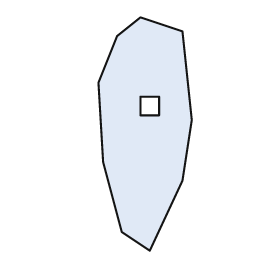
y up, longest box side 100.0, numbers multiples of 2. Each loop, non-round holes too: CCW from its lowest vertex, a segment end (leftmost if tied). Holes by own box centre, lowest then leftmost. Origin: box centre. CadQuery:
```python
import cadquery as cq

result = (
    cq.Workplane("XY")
    .moveTo(2.0, -50.0)
    .lineTo(16.0, -20.0)
    .lineTo(20.0, 6.0)
    .lineTo(16.0, 44.0)
    .lineTo(-2.0, 50.0)
    .lineTo(-12.0, 42.0)
    .lineTo(-20.0, 22.0)
    .lineTo(-18.0, -12.0)
    .lineTo(-10.0, -42.0)
    .close()
    .moveTo(-2.0, 8.0)
    .lineTo(6.0, 8.0)
    .lineTo(6.0, 16.0)
    .lineTo(-2.0, 16.0)
    .close()
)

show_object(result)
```